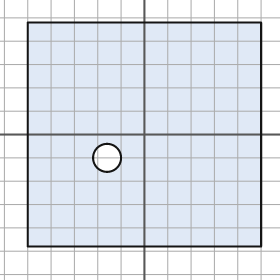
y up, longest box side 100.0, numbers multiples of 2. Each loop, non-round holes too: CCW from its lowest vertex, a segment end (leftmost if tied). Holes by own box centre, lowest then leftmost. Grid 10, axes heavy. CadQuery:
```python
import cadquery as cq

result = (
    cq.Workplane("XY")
    .moveTo(-50.0, -48.0)
    .lineTo(50.0, -48.0)
    .lineTo(50.0, 48.0)
    .lineTo(-50.0, 48.0)
    .close()
    .moveTo(-16.0, -10.0)
    .circle(6.0)
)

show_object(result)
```